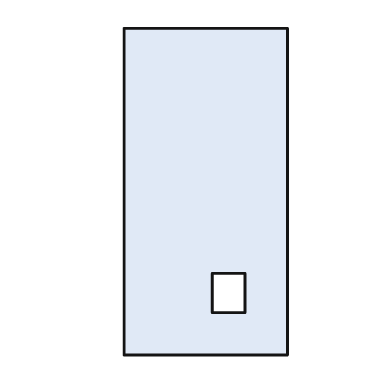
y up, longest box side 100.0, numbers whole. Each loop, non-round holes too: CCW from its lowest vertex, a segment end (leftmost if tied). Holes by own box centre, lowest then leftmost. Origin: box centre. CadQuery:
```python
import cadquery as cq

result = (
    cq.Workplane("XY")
    .moveTo(-25.0, -50.0)
    .lineTo(25.0, -50.0)
    .lineTo(25.0, 50.0)
    .lineTo(-25.0, 50.0)
    .close()
    .moveTo(2.0, -37.0)
    .lineTo(12.0, -37.0)
    .lineTo(12.0, -25.0)
    .lineTo(2.0, -25.0)
    .close()
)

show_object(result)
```